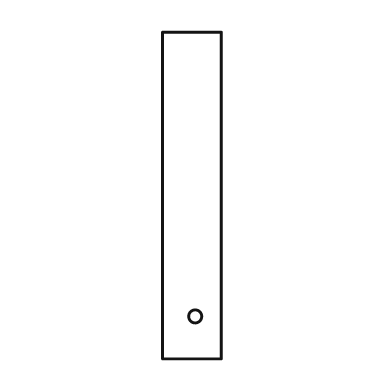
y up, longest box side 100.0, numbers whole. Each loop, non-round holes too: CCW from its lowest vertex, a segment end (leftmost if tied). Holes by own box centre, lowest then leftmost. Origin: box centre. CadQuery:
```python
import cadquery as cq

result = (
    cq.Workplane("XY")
    .moveTo(-9.0, -50.0)
    .lineTo(9.0, -50.0)
    .lineTo(9.0, 50.0)
    .lineTo(-9.0, 50.0)
    .close()
    .moveTo(1.0, -37.0)
    .circle(2.0)
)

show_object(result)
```